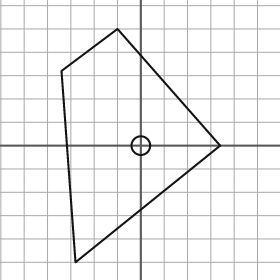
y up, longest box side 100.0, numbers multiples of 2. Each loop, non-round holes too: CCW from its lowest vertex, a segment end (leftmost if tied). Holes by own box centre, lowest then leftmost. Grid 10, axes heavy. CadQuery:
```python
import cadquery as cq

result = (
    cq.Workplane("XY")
    .moveTo(-28.0, -50.0)
    .lineTo(34.0, 0.0)
    .lineTo(-10.0, 50.0)
    .lineTo(-34.0, 32.0)
    .close()
    .moveTo(0.0, 0.0)
    .circle(4.0)
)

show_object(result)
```